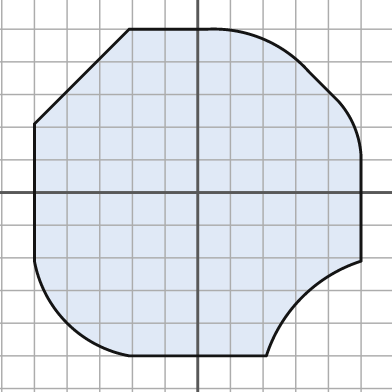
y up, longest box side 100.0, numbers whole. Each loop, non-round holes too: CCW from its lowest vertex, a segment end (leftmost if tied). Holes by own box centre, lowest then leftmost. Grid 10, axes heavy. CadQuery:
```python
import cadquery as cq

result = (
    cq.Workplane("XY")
    .moveTo(-21.0, -50.0)
    .lineTo(21.0, -50.0)
    .threePointArc((32.0, -32.0), (50.0, -21.0))
    .lineTo(50.0, 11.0)
    .threePointArc((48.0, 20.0), (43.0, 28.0))
    .lineTo(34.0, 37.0)
    .threePointArc((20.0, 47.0), (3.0, 50.0))
    .lineTo(-21.0, 50.0)
    .lineTo(-50.0, 21.0)
    .lineTo(-50.0, -21.0)
    .threePointArc((-40.0, -40.0), (-21.0, -50.0))
    .close()
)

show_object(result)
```